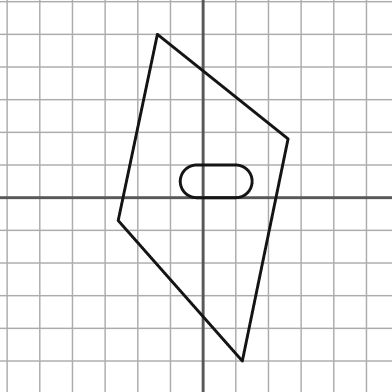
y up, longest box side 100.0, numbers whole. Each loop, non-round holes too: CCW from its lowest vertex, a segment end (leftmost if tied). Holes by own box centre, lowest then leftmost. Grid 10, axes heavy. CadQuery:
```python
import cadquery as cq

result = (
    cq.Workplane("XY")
    .moveTo(12.0, -50.0)
    .lineTo(26.0, 18.0)
    .lineTo(-14.0, 50.0)
    .lineTo(-26.0, -7.0)
    .close()
    .moveTo(-2.0, 0.0)
    .lineTo(10.0, 0.0)
    .threePointArc((15.0, 5.0), (10.0, 10.0))
    .lineTo(-2.0, 10.0)
    .threePointArc((-7.0, 5.0), (-2.0, 0.0))
    .close()
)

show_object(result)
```